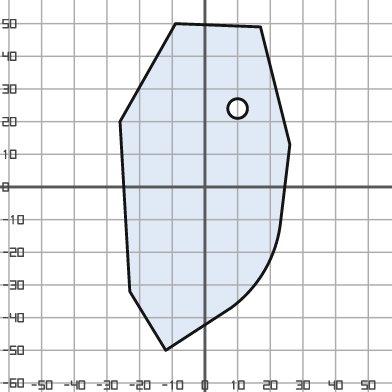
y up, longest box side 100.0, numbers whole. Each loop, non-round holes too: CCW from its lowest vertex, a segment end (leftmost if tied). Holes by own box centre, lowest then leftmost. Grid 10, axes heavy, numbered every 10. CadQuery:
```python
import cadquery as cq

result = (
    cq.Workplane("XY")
    .moveTo(-12.0, -50.0)
    .lineTo(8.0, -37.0)
    .threePointArc((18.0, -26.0), (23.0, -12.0))
    .lineTo(26.0, 13.0)
    .lineTo(17.0, 49.0)
    .lineTo(-9.0, 50.0)
    .lineTo(-26.0, 20.0)
    .lineTo(-23.0, -32.0)
    .close()
    .moveTo(10.0, 24.0)
    .circle(3.0)
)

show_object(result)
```